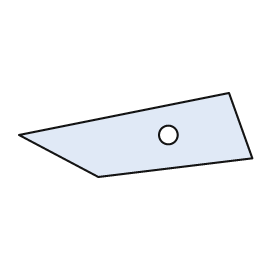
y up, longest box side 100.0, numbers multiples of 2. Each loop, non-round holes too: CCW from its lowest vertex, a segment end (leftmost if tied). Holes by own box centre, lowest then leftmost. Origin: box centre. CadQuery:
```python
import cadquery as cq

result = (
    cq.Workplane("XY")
    .moveTo(-16.0, -18.0)
    .lineTo(50.0, -10.0)
    .lineTo(40.0, 18.0)
    .lineTo(-50.0, 0.0)
    .close()
    .moveTo(14.0, 0.0)
    .circle(4.0)
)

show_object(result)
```